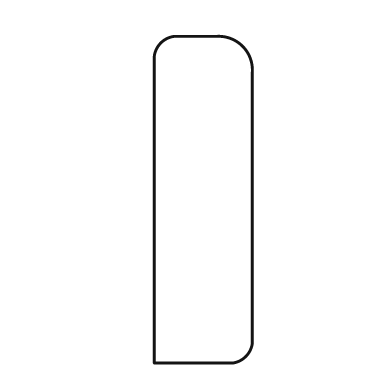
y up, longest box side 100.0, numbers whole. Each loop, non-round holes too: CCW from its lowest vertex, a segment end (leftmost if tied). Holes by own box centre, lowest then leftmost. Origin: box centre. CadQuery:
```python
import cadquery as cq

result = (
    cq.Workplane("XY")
    .moveTo(-15.0, -50.0)
    .lineTo(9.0, -50.0)
    .threePointArc((13.0, -48.0), (15.0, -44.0))
    .lineTo(15.0, 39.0)
    .threePointArc((12.0, 47.0), (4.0, 50.0))
    .lineTo(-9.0, 50.0)
    .threePointArc((-13.0, 48.0), (-15.0, 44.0))
    .close()
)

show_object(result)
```